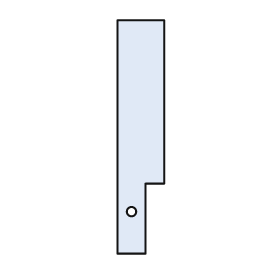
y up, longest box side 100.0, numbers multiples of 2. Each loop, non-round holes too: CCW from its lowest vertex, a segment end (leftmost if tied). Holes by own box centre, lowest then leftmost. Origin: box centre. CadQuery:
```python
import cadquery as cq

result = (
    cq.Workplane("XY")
    .moveTo(-10.0, -50.0)
    .lineTo(2.0, -50.0)
    .lineTo(2.0, -20.0)
    .lineTo(10.0, -20.0)
    .lineTo(10.0, 50.0)
    .lineTo(-10.0, 50.0)
    .close()
    .moveTo(-4.0, -32.0)
    .circle(2.0)
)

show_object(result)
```